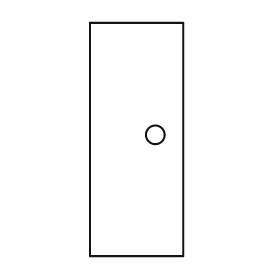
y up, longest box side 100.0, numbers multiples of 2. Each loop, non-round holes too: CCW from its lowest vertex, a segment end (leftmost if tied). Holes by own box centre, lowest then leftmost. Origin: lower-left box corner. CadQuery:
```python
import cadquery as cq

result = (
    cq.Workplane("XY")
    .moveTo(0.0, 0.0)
    .lineTo(40.0, 0.0)
    .lineTo(40.0, 100.0)
    .lineTo(0.0, 100.0)
    .close()
    .moveTo(28.0, 52.0)
    .circle(4.0)
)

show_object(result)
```